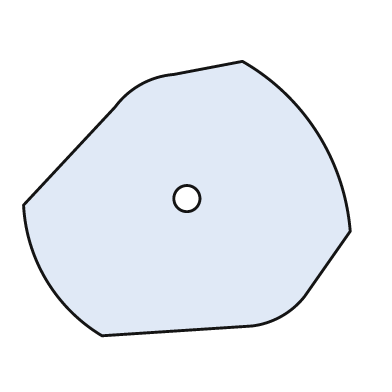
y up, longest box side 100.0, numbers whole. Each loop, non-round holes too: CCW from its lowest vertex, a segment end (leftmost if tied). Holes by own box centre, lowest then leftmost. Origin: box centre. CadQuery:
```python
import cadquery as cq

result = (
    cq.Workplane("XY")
    .moveTo(-26.0, -42.0)
    .lineTo(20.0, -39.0)
    .threePointArc((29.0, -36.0), (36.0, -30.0))
    .lineTo(50.0, -10.0)
    .threePointArc((40.0, 20.0), (17.0, 42.0))
    .lineTo(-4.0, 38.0)
    .threePointArc((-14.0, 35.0), (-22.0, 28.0))
    .lineTo(-50.0, -2.0)
    .threePointArc((-43.0, -25.0), (-26.0, -42.0))
    .close()
    .moveTo(0.0, 0.0)
    .circle(4.0)
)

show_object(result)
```